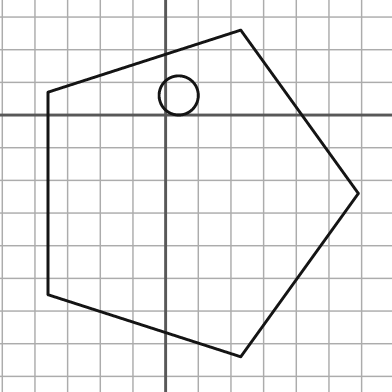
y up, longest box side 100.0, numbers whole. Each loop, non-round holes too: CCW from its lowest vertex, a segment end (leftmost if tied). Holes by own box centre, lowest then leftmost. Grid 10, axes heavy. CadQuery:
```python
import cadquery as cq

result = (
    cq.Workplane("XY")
    .moveTo(23.0, -74.0)
    .lineTo(59.0, -24.0)
    .lineTo(23.0, 26.0)
    .lineTo(-36.0, 7.0)
    .lineTo(-36.0, -55.0)
    .close()
    .moveTo(4.0, 6.0)
    .circle(6.0)
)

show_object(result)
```